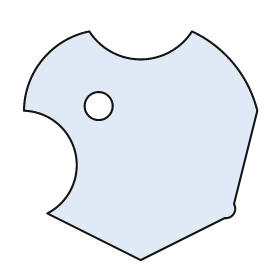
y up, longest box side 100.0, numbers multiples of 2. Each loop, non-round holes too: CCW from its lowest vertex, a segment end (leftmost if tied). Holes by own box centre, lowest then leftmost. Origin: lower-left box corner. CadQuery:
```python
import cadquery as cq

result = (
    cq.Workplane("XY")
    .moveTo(50.0, 0.0)
    .lineTo(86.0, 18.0)
    .threePointArc((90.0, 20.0), (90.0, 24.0))
    .lineTo(100.0, 64.0)
    .threePointArc((90.0, 84.0), (72.0, 98.0))
    .threePointArc((50.0, 86.0), (28.0, 98.0))
    .threePointArc((8.0, 86.0), (0.0, 64.0))
    .threePointArc((22.0, 46.0), (10.0, 20.0))
    .close()
    .moveTo(32.0, 66.0)
    .circle(6.0)
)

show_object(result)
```